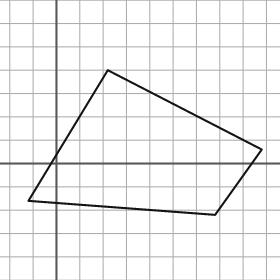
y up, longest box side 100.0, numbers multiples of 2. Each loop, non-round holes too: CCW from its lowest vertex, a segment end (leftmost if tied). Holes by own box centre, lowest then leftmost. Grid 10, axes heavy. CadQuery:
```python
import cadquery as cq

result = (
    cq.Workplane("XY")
    .moveTo(68.0, -22.0)
    .lineTo(88.0, 6.0)
    .lineTo(22.0, 40.0)
    .lineTo(-12.0, -16.0)
    .close()
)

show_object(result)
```